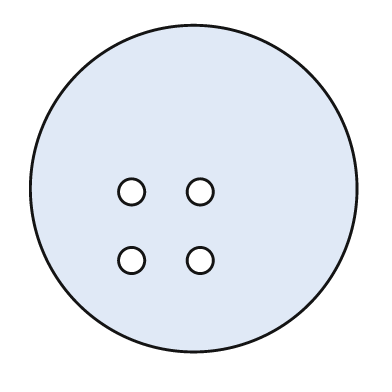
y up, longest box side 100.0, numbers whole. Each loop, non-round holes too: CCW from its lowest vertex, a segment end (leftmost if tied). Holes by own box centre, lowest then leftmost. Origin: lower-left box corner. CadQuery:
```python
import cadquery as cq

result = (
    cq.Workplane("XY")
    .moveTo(50.0, 50.0)
    .circle(50.0)
    .moveTo(31.0, 28.0)
    .circle(4.0)
    .moveTo(52.0, 28.0)
    .circle(4.0)
    .moveTo(31.0, 49.0)
    .circle(4.0)
    .moveTo(52.0, 49.0)
    .circle(4.0)
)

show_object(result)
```